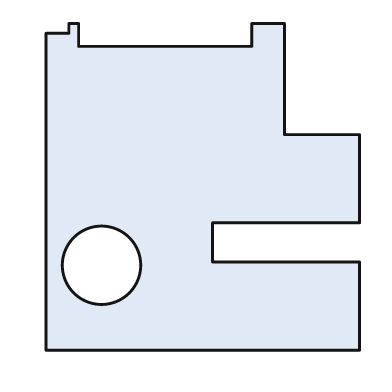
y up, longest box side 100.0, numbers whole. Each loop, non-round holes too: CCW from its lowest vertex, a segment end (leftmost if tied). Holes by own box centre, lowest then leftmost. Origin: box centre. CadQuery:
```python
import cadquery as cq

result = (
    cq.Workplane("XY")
    .moveTo(-48.0, -50.0)
    .lineTo(48.0, -50.0)
    .lineTo(48.0, -23.0)
    .lineTo(3.0, -23.0)
    .lineTo(3.0, -11.0)
    .lineTo(48.0, -11.0)
    .lineTo(48.0, 16.0)
    .lineTo(25.0, 16.0)
    .lineTo(25.0, 50.0)
    .lineTo(15.0, 50.0)
    .lineTo(15.0, 43.0)
    .lineTo(-38.0, 43.0)
    .lineTo(-38.0, 50.0)
    .lineTo(-41.0, 50.0)
    .lineTo(-41.0, 47.0)
    .lineTo(-48.0, 47.0)
    .close()
    .moveTo(-31.0, -24.0)
    .circle(12.0)
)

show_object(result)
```